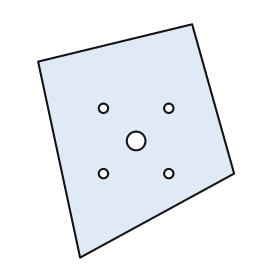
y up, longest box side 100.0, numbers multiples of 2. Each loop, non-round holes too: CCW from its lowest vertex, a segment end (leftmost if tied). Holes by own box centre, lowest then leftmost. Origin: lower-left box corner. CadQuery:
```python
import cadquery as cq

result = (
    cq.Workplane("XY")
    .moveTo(18.0, 0.0)
    .lineTo(84.0, 36.0)
    .lineTo(66.0, 100.0)
    .lineTo(0.0, 84.0)
    .close()
    .moveTo(28.0, 36.0)
    .circle(2.0)
    .moveTo(56.0, 36.0)
    .circle(2.0)
    .moveTo(42.0, 50.0)
    .circle(4.0)
    .moveTo(28.0, 64.0)
    .circle(2.0)
    .moveTo(56.0, 64.0)
    .circle(2.0)
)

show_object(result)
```